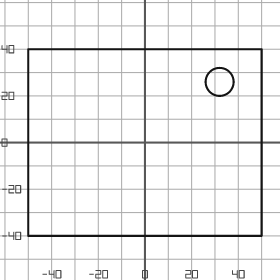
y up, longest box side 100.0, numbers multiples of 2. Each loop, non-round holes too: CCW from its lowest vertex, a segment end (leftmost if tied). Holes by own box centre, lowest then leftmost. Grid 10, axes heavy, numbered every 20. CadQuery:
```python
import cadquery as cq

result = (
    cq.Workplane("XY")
    .moveTo(-50.0, -40.0)
    .lineTo(50.0, -40.0)
    .lineTo(50.0, 40.0)
    .lineTo(-50.0, 40.0)
    .close()
    .moveTo(32.0, 26.0)
    .circle(6.0)
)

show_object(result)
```